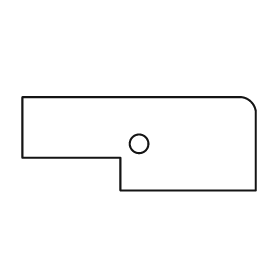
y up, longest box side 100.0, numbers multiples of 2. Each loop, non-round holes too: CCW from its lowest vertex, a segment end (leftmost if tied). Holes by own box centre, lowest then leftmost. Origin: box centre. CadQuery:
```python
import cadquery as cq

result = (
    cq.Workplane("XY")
    .moveTo(-8.0, -20.0)
    .lineTo(50.0, -20.0)
    .lineTo(50.0, 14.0)
    .threePointArc((48.0, 18.0), (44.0, 20.0))
    .lineTo(-50.0, 20.0)
    .lineTo(-50.0, -6.0)
    .lineTo(-8.0, -6.0)
    .close()
    .moveTo(0.0, 0.0)
    .circle(4.0)
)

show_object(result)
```